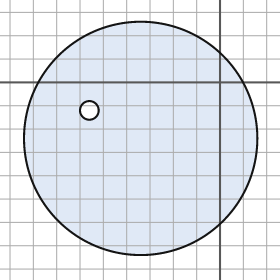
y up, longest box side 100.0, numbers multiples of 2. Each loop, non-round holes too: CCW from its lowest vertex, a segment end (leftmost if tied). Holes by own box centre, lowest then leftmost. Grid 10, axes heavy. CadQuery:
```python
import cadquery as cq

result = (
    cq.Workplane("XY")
    .moveTo(-34.0, -24.0)
    .circle(50.0)
    .moveTo(-56.0, -12.0)
    .circle(4.0)
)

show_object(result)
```